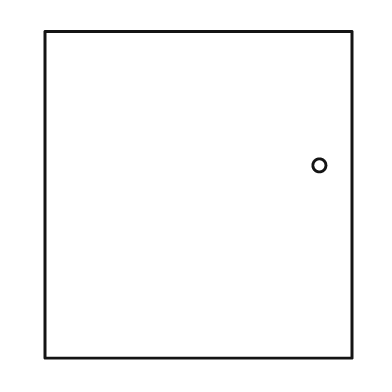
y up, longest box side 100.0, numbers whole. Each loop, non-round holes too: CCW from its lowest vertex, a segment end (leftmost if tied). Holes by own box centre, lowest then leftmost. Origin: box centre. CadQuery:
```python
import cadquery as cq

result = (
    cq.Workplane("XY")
    .moveTo(-47.0, -50.0)
    .lineTo(47.0, -50.0)
    .lineTo(47.0, 50.0)
    .lineTo(-47.0, 50.0)
    .close()
    .moveTo(37.0, 9.0)
    .circle(2.0)
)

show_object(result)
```